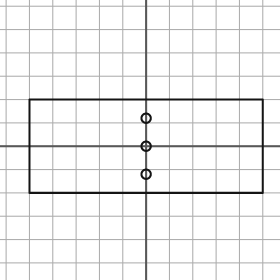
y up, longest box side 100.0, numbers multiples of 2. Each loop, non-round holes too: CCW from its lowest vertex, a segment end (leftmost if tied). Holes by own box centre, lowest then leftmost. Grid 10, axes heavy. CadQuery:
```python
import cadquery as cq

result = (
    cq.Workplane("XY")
    .moveTo(-50.0, -20.0)
    .lineTo(50.0, -20.0)
    .lineTo(50.0, 20.0)
    .lineTo(-50.0, 20.0)
    .close()
    .moveTo(0.0, -12.0)
    .circle(2.0)
    .moveTo(0.0, 0.0)
    .circle(2.0)
    .moveTo(0.0, 12.0)
    .circle(2.0)
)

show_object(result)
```